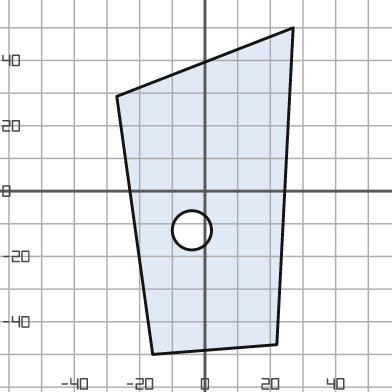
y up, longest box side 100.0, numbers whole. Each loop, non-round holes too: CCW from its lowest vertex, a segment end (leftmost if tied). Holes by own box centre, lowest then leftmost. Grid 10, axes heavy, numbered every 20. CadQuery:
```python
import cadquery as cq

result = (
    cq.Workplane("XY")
    .moveTo(-16.0, -50.0)
    .lineTo(22.0, -47.0)
    .lineTo(27.0, 50.0)
    .lineTo(-27.0, 29.0)
    .close()
    .moveTo(-4.0, -12.0)
    .circle(6.0)
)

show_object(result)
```